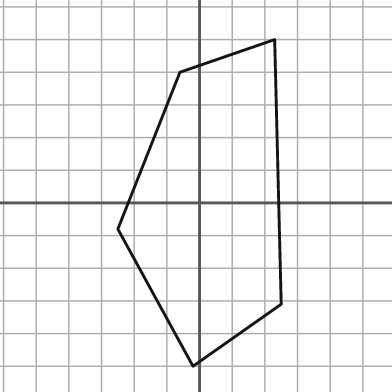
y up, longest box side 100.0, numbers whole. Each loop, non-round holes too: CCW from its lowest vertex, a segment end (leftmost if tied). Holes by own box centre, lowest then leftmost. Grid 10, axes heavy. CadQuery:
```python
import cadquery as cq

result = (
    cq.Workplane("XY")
    .moveTo(-2.0, -50.0)
    .lineTo(25.0, -31.0)
    .lineTo(23.0, 50.0)
    .lineTo(-6.0, 40.0)
    .lineTo(-25.0, -8.0)
    .close()
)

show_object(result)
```